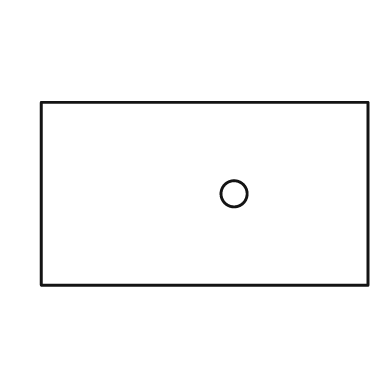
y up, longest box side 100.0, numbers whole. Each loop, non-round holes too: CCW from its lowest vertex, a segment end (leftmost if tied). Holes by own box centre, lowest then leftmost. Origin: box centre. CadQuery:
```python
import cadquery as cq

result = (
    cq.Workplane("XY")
    .moveTo(-50.0, -28.0)
    .lineTo(50.0, -28.0)
    .lineTo(50.0, 28.0)
    .lineTo(-50.0, 28.0)
    .close()
    .moveTo(9.0, 0.0)
    .circle(4.0)
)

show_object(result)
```